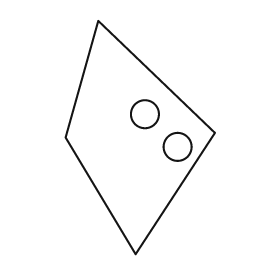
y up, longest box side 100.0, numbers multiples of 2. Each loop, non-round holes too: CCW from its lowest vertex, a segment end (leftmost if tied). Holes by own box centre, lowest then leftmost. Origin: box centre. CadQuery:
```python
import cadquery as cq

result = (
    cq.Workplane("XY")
    .moveTo(-2.0, -50.0)
    .lineTo(32.0, 2.0)
    .lineTo(-18.0, 50.0)
    .lineTo(-32.0, 0.0)
    .close()
    .moveTo(16.0, -4.0)
    .circle(6.0)
    .moveTo(2.0, 10.0)
    .circle(6.0)
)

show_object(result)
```